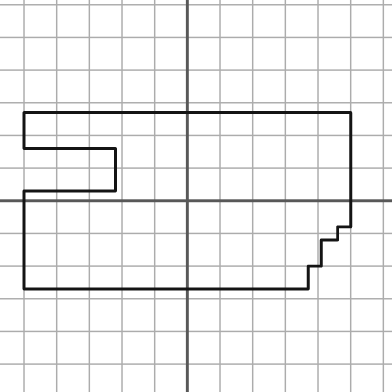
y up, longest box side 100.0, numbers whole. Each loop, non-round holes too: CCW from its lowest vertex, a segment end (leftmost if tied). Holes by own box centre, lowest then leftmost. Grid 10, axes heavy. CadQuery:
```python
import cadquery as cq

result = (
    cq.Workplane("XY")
    .moveTo(-50.0, -27.0)
    .lineTo(37.0, -27.0)
    .lineTo(37.0, -20.0)
    .lineTo(41.0, -20.0)
    .lineTo(41.0, -12.0)
    .lineTo(46.0, -12.0)
    .lineTo(46.0, -8.0)
    .lineTo(50.0, -8.0)
    .lineTo(50.0, 27.0)
    .lineTo(-50.0, 27.0)
    .lineTo(-50.0, 16.0)
    .lineTo(-22.0, 16.0)
    .lineTo(-22.0, 3.0)
    .lineTo(-50.0, 3.0)
    .close()
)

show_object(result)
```